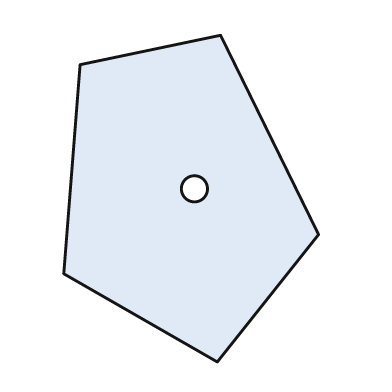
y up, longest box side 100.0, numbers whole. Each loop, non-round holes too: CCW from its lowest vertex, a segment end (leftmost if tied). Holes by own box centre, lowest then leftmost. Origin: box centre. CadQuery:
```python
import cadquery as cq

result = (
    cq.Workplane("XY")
    .moveTo(8.0, -50.0)
    .lineTo(39.0, -11.0)
    .lineTo(9.0, 50.0)
    .lineTo(-34.0, 41.0)
    .lineTo(-39.0, -23.0)
    .close()
    .moveTo(1.0, 3.0)
    .circle(4.0)
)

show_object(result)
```